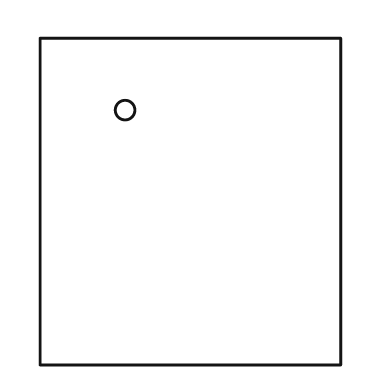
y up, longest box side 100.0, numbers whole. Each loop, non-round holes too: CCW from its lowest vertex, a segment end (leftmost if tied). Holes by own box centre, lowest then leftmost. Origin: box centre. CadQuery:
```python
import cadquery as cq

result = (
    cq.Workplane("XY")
    .moveTo(-46.0, -50.0)
    .lineTo(46.0, -50.0)
    .lineTo(46.0, 50.0)
    .lineTo(-46.0, 50.0)
    .close()
    .moveTo(-20.0, 28.0)
    .circle(3.0)
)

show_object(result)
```